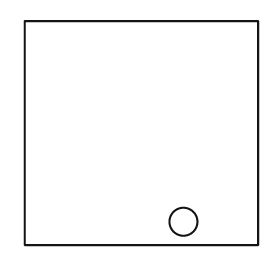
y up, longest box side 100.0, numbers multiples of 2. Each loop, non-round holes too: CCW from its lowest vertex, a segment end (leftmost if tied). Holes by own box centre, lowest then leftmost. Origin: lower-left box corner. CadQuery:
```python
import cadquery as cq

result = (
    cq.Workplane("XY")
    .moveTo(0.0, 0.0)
    .lineTo(100.0, 0.0)
    .lineTo(100.0, 96.0)
    .lineTo(0.0, 96.0)
    .close()
    .moveTo(68.0, 10.0)
    .circle(6.0)
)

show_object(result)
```